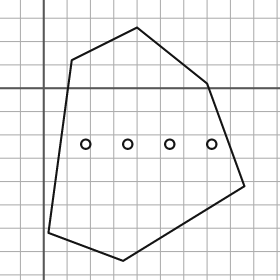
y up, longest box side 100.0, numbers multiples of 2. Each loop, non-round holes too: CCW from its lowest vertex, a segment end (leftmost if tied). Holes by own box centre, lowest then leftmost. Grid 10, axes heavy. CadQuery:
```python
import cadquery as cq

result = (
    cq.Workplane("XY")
    .moveTo(34.0, -74.0)
    .lineTo(86.0, -42.0)
    .lineTo(70.0, 2.0)
    .lineTo(40.0, 26.0)
    .lineTo(12.0, 12.0)
    .lineTo(2.0, -62.0)
    .close()
    .moveTo(18.0, -24.0)
    .circle(2.0)
    .moveTo(36.0, -24.0)
    .circle(2.0)
    .moveTo(54.0, -24.0)
    .circle(2.0)
    .moveTo(72.0, -24.0)
    .circle(2.0)
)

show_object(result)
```